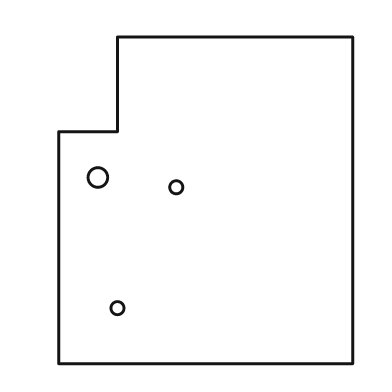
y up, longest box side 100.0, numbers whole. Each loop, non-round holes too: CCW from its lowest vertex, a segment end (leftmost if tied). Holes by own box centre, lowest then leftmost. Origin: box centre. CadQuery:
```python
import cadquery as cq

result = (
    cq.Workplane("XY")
    .moveTo(-45.0, -50.0)
    .lineTo(45.0, -50.0)
    .lineTo(45.0, 50.0)
    .lineTo(-27.0, 50.0)
    .lineTo(-27.0, 21.0)
    .lineTo(-45.0, 21.0)
    .close()
    .moveTo(-27.0, -33.0)
    .circle(2.0)
    .moveTo(-9.0, 4.0)
    .circle(2.0)
    .moveTo(-33.0, 7.0)
    .circle(3.0)
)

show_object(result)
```